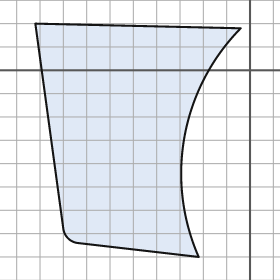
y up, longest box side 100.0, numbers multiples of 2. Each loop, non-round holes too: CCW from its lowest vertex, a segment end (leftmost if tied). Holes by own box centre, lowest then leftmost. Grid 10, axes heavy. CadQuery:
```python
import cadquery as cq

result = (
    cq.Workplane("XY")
    .moveTo(-22.0, -80.0)
    .threePointArc((-28.0, -28.0), (-4.0, 18.0))
    .lineTo(-92.0, 20.0)
    .lineTo(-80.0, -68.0)
    .threePointArc((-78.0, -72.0), (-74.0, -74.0))
    .close()
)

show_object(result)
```